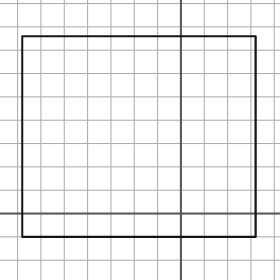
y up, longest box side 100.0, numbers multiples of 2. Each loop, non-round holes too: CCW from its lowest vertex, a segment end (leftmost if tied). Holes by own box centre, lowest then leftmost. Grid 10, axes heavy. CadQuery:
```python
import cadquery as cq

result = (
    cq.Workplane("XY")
    .moveTo(-68.0, -10.0)
    .lineTo(32.0, -10.0)
    .lineTo(32.0, 76.0)
    .lineTo(-68.0, 76.0)
    .close()
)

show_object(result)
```